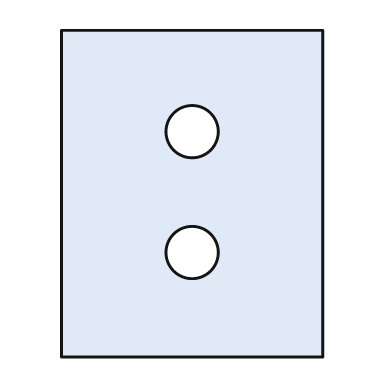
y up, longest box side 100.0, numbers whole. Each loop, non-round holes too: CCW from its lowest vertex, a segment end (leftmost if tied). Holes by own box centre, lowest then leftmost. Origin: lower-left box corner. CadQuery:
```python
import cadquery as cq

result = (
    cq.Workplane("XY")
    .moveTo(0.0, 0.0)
    .lineTo(80.0, 0.0)
    .lineTo(80.0, 100.0)
    .lineTo(0.0, 100.0)
    .close()
    .moveTo(40.0, 32.0)
    .circle(8.0)
    .moveTo(40.0, 69.0)
    .circle(8.0)
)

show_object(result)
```